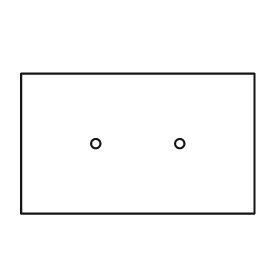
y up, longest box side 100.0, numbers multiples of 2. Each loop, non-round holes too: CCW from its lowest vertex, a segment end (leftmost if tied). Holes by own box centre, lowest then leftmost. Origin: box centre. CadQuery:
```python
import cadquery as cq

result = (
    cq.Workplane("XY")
    .moveTo(-50.0, -30.0)
    .lineTo(50.0, -30.0)
    .lineTo(50.0, 30.0)
    .lineTo(-50.0, 30.0)
    .close()
    .moveTo(-18.0, 0.0)
    .circle(2.0)
    .moveTo(18.0, 0.0)
    .circle(2.0)
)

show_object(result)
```